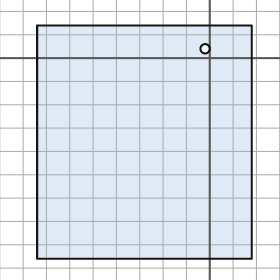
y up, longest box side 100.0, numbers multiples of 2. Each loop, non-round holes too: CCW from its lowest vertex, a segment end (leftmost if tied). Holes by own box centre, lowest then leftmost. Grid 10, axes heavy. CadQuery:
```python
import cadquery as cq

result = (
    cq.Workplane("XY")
    .moveTo(-74.0, -86.0)
    .lineTo(18.0, -86.0)
    .lineTo(18.0, 14.0)
    .lineTo(-74.0, 14.0)
    .close()
    .moveTo(-2.0, 4.0)
    .circle(2.0)
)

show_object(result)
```